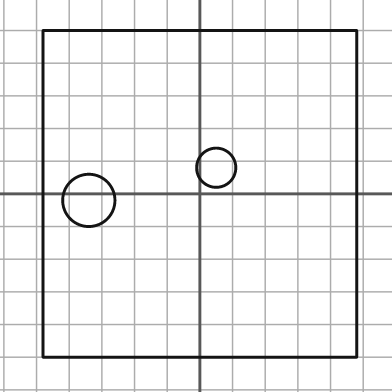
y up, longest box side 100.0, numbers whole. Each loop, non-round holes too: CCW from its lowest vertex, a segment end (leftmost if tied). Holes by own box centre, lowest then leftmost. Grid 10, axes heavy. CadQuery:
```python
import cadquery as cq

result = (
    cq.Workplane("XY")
    .moveTo(-48.0, -50.0)
    .lineTo(48.0, -50.0)
    .lineTo(48.0, 50.0)
    .lineTo(-48.0, 50.0)
    .close()
    .moveTo(-34.0, -2.0)
    .circle(8.0)
    .moveTo(5.0, 8.0)
    .circle(6.0)
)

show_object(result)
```